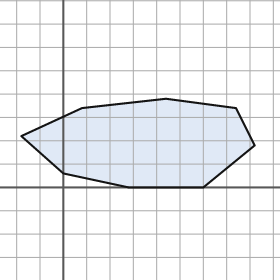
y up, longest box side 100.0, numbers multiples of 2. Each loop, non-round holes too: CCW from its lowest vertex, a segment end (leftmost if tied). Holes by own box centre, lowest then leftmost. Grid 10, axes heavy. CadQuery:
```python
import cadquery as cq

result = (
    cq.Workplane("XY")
    .moveTo(28.0, 0.0)
    .lineTo(60.0, 0.0)
    .lineTo(82.0, 18.0)
    .lineTo(74.0, 34.0)
    .lineTo(44.0, 38.0)
    .lineTo(8.0, 34.0)
    .lineTo(-18.0, 22.0)
    .lineTo(0.0, 6.0)
    .close()
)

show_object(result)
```